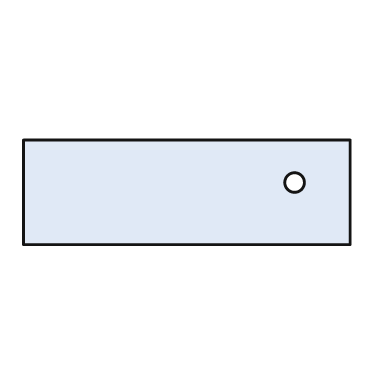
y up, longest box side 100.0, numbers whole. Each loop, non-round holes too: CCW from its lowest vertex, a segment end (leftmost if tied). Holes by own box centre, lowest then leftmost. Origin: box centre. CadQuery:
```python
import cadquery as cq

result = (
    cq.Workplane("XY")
    .moveTo(-50.0, -16.0)
    .lineTo(50.0, -16.0)
    .lineTo(50.0, 16.0)
    .lineTo(-50.0, 16.0)
    .close()
    .moveTo(33.0, 3.0)
    .circle(3.0)
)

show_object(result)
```